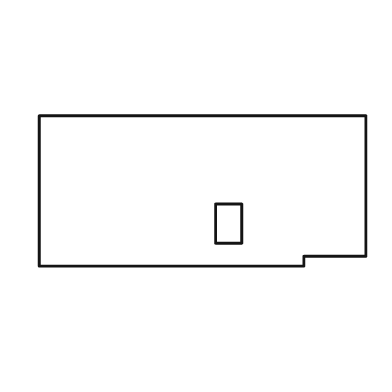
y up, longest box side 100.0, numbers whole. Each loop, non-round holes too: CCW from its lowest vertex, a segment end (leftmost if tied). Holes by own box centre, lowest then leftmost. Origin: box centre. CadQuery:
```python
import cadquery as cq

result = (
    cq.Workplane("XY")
    .moveTo(-50.0, -23.0)
    .lineTo(31.0, -23.0)
    .lineTo(31.0, -20.0)
    .lineTo(50.0, -20.0)
    .lineTo(50.0, 23.0)
    .lineTo(-50.0, 23.0)
    .close()
    .moveTo(4.0, -16.0)
    .lineTo(12.0, -16.0)
    .lineTo(12.0, -4.0)
    .lineTo(4.0, -4.0)
    .close()
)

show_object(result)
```